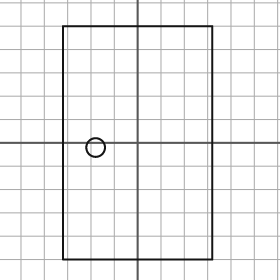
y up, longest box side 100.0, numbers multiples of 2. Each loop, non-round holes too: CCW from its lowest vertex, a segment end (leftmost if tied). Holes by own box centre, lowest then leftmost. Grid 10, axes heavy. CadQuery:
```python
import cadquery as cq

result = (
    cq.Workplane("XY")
    .moveTo(-32.0, -50.0)
    .lineTo(32.0, -50.0)
    .lineTo(32.0, 50.0)
    .lineTo(-32.0, 50.0)
    .close()
    .moveTo(-18.0, -2.0)
    .circle(4.0)
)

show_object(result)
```